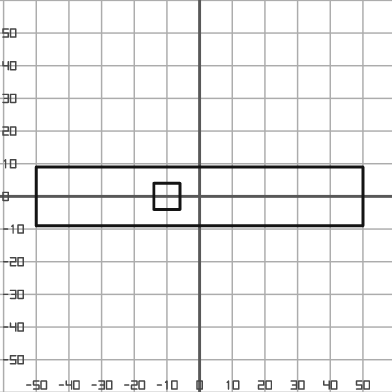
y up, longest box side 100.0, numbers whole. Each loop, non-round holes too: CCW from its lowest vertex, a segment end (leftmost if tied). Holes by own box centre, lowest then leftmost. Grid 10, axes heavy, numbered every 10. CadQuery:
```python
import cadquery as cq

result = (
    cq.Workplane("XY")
    .moveTo(-50.0, -9.0)
    .lineTo(50.0, -9.0)
    .lineTo(50.0, 9.0)
    .lineTo(-50.0, 9.0)
    .close()
    .moveTo(-14.0, -4.0)
    .lineTo(-6.0, -4.0)
    .lineTo(-6.0, 4.0)
    .lineTo(-14.0, 4.0)
    .close()
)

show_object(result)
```